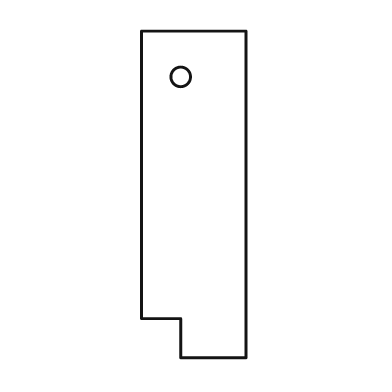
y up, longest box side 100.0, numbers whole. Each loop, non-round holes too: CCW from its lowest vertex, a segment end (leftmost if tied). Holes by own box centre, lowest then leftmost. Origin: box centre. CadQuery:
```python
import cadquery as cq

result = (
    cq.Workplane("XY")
    .moveTo(-4.0, -50.0)
    .lineTo(16.0, -50.0)
    .lineTo(16.0, 50.0)
    .lineTo(-16.0, 50.0)
    .lineTo(-16.0, -38.0)
    .lineTo(-4.0, -38.0)
    .close()
    .moveTo(-4.0, 36.0)
    .circle(3.0)
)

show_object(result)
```